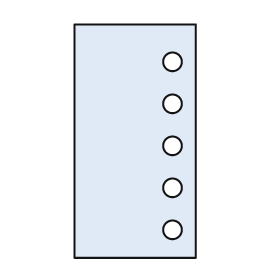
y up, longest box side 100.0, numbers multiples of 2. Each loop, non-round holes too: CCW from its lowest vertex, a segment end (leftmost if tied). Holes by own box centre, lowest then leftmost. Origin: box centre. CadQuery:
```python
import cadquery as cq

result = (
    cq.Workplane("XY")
    .moveTo(-26.0, -50.0)
    .lineTo(26.0, -50.0)
    .lineTo(26.0, 50.0)
    .lineTo(-26.0, 50.0)
    .close()
    .moveTo(16.0, -38.0)
    .circle(4.0)
    .moveTo(16.0, -20.0)
    .circle(4.0)
    .moveTo(16.0, -2.0)
    .circle(4.0)
    .moveTo(16.0, 16.0)
    .circle(4.0)
    .moveTo(16.0, 34.0)
    .circle(4.0)
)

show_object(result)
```